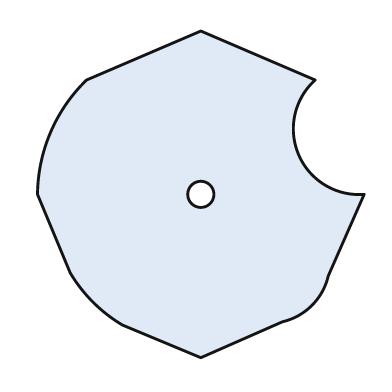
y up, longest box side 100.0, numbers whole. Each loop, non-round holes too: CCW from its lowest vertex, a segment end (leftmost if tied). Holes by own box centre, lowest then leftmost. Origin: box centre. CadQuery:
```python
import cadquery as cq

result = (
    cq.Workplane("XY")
    .moveTo(0.0, -50.0)
    .lineTo(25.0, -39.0)
    .threePointArc((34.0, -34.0), (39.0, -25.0))
    .lineTo(50.0, 0.0)
    .threePointArc((30.0, 12.0), (35.0, 35.0))
    .lineTo(0.0, 50.0)
    .lineTo(-35.0, 35.0)
    .threePointArc((-46.0, 19.0), (-50.0, 0.0))
    .lineTo(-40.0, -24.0)
    .threePointArc((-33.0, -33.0), (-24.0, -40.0))
    .close()
    .moveTo(0.0, 0.0)
    .circle(4.0)
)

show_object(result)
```